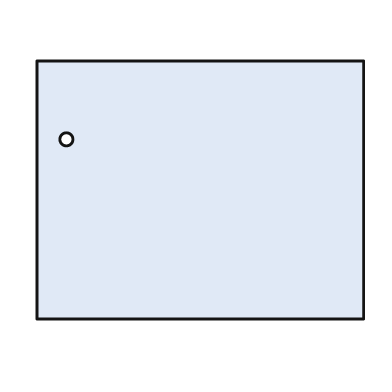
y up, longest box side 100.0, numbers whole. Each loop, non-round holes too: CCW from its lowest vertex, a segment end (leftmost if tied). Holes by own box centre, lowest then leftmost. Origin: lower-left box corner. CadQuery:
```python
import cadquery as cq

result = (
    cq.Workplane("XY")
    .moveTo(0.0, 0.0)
    .lineTo(100.0, 0.0)
    .lineTo(100.0, 79.0)
    .lineTo(0.0, 79.0)
    .close()
    .moveTo(9.0, 55.0)
    .circle(2.0)
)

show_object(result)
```